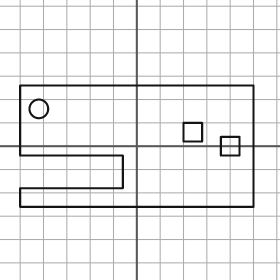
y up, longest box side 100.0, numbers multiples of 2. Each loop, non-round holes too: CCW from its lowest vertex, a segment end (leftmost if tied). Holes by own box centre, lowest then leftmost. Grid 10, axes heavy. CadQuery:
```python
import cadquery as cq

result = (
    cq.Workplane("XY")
    .moveTo(-50.0, -26.0)
    .lineTo(50.0, -26.0)
    .lineTo(50.0, 26.0)
    .lineTo(-50.0, 26.0)
    .lineTo(-50.0, -4.0)
    .lineTo(-6.0, -4.0)
    .lineTo(-6.0, -18.0)
    .lineTo(-50.0, -18.0)
    .close()
    .moveTo(36.0, -4.0)
    .lineTo(44.0, -4.0)
    .lineTo(44.0, 4.0)
    .lineTo(36.0, 4.0)
    .close()
    .moveTo(20.0, 2.0)
    .lineTo(28.0, 2.0)
    .lineTo(28.0, 10.0)
    .lineTo(20.0, 10.0)
    .close()
    .moveTo(-42.0, 16.0)
    .circle(4.0)
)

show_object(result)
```